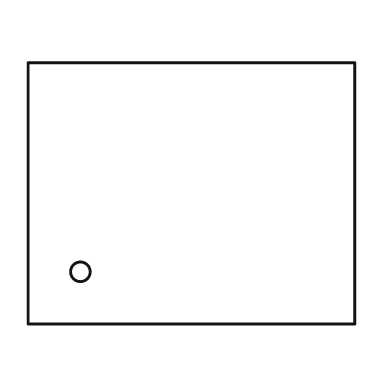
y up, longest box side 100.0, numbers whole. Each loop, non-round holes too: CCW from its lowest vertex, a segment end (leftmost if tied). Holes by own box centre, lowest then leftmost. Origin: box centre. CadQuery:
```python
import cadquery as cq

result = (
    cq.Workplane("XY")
    .moveTo(-50.0, -40.0)
    .lineTo(50.0, -40.0)
    .lineTo(50.0, 40.0)
    .lineTo(-50.0, 40.0)
    .close()
    .moveTo(-34.0, -24.0)
    .circle(3.0)
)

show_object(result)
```